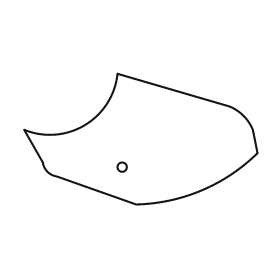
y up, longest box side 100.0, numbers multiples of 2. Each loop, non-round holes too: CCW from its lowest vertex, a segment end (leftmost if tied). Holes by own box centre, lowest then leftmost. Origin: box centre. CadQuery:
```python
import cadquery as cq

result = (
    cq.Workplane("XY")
    .moveTo(-2.0, -28.0)
    .threePointArc((26.0, -22.0), (50.0, -6.0))
    .lineTo(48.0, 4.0)
    .threePointArc((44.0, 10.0), (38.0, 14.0))
    .lineTo(-10.0, 28.0)
    .threePointArc((-24.0, 6.0), (-50.0, 4.0))
    .lineTo(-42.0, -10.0)
    .threePointArc((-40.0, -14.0), (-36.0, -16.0))
    .close()
    .moveTo(-8.0, -12.0)
    .circle(2.0)
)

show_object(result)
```